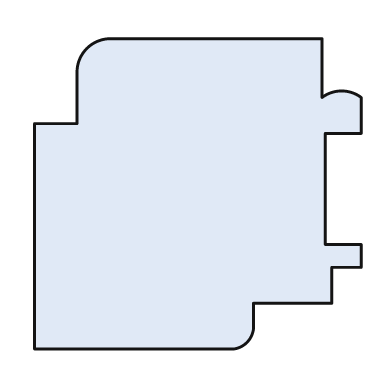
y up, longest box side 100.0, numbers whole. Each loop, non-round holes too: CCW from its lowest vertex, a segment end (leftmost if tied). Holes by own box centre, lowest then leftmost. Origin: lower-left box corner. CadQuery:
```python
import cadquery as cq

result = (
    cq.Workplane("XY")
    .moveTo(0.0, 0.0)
    .lineTo(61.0, 0.0)
    .threePointArc((65.0, 2.0), (67.0, 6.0))
    .lineTo(67.0, 14.0)
    .lineTo(91.0, 14.0)
    .lineTo(91.0, 25.0)
    .lineTo(100.0, 25.0)
    .lineTo(100.0, 32.0)
    .lineTo(89.0, 32.0)
    .lineTo(89.0, 66.0)
    .lineTo(100.0, 66.0)
    .lineTo(100.0, 77.0)
    .threePointArc((94.0, 79.0), (88.0, 77.0))
    .lineTo(88.0, 95.0)
    .lineTo(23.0, 95.0)
    .threePointArc((16.0, 92.0), (13.0, 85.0))
    .lineTo(13.0, 69.0)
    .lineTo(0.0, 69.0)
    .close()
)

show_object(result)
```